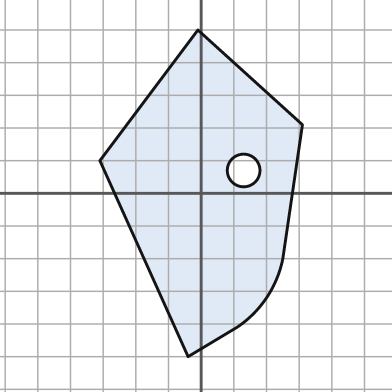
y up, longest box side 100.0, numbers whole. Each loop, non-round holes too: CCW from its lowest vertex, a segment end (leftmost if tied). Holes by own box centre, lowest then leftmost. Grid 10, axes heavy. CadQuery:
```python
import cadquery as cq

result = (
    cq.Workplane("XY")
    .moveTo(-4.0, -50.0)
    .lineTo(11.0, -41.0)
    .threePointArc((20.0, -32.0), (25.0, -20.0))
    .lineTo(31.0, 21.0)
    .lineTo(-1.0, 50.0)
    .lineTo(-31.0, 10.0)
    .close()
    .moveTo(13.0, 7.0)
    .circle(5.0)
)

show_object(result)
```